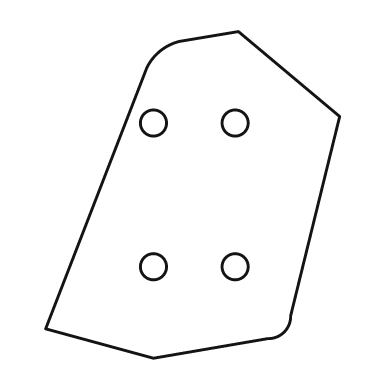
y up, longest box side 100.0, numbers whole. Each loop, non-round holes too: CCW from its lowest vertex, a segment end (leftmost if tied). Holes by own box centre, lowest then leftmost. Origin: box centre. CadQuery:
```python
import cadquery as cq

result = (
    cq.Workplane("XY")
    .moveTo(-12.0, -50.0)
    .lineTo(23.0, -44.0)
    .threePointArc((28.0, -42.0), (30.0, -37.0))
    .lineTo(45.0, 24.0)
    .lineTo(14.0, 50.0)
    .lineTo(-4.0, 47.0)
    .threePointArc((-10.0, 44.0), (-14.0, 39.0))
    .lineTo(-45.0, -41.0)
    .close()
    .moveTo(-12.0, -22.0)
    .circle(4.0)
    .moveTo(13.0, -22.0)
    .circle(4.0)
    .moveTo(-12.0, 22.0)
    .circle(4.0)
    .moveTo(13.0, 22.0)
    .circle(4.0)
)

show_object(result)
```